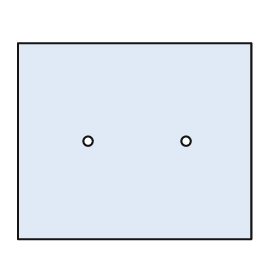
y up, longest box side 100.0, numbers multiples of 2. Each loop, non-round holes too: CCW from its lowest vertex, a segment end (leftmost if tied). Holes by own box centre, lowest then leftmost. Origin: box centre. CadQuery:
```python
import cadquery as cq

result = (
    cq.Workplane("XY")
    .moveTo(-50.0, -42.0)
    .lineTo(50.0, -42.0)
    .lineTo(50.0, 42.0)
    .lineTo(-50.0, 42.0)
    .close()
    .moveTo(-20.0, 0.0)
    .circle(2.0)
    .moveTo(22.0, 0.0)
    .circle(2.0)
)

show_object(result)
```